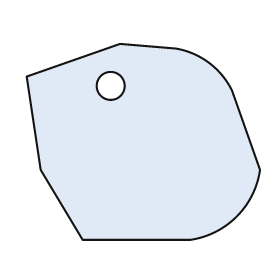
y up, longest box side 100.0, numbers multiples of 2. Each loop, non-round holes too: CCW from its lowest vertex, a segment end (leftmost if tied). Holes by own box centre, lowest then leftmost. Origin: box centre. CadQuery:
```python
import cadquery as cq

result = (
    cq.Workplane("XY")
    .moveTo(-26.0, -42.0)
    .lineTo(20.0, -42.0)
    .threePointArc((40.0, -32.0), (50.0, -12.0))
    .lineTo(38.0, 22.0)
    .threePointArc((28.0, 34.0), (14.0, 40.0))
    .lineTo(-10.0, 42.0)
    .lineTo(-50.0, 28.0)
    .lineTo(-44.0, -12.0)
    .close()
    .moveTo(-14.0, 24.0)
    .circle(6.0)
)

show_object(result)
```